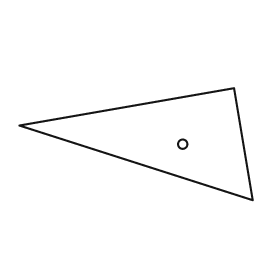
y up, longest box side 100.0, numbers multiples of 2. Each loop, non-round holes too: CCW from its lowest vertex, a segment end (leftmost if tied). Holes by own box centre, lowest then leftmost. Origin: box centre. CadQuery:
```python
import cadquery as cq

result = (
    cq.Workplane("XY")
    .moveTo(50.0, -24.0)
    .lineTo(42.0, 24.0)
    .lineTo(-50.0, 8.0)
    .close()
    .moveTo(20.0, 0.0)
    .circle(2.0)
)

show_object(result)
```